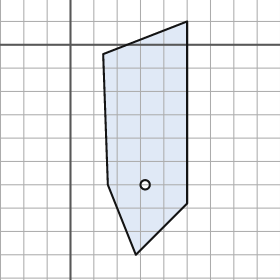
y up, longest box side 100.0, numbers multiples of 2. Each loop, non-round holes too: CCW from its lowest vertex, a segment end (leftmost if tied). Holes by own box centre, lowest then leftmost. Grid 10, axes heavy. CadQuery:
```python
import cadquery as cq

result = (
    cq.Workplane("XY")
    .moveTo(28.0, -90.0)
    .lineTo(50.0, -68.0)
    .lineTo(50.0, 10.0)
    .lineTo(14.0, -4.0)
    .lineTo(16.0, -60.0)
    .close()
    .moveTo(32.0, -60.0)
    .circle(2.0)
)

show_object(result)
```